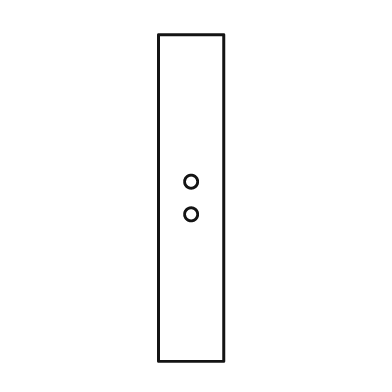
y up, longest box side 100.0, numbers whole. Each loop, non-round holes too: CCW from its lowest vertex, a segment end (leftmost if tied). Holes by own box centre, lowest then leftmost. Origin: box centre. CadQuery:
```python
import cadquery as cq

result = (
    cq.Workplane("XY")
    .moveTo(-10.0, -50.0)
    .lineTo(10.0, -50.0)
    .lineTo(10.0, 50.0)
    .lineTo(-10.0, 50.0)
    .close()
    .moveTo(0.0, -5.0)
    .circle(2.0)
    .moveTo(0.0, 5.0)
    .circle(2.0)
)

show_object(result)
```